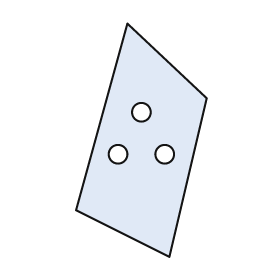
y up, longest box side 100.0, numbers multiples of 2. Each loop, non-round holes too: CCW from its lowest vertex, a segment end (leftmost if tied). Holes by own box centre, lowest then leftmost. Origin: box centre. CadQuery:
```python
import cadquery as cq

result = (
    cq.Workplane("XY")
    .moveTo(12.0, -50.0)
    .lineTo(28.0, 18.0)
    .lineTo(-6.0, 50.0)
    .lineTo(-28.0, -30.0)
    .close()
    .moveTo(-10.0, -6.0)
    .circle(4.0)
    .moveTo(10.0, -6.0)
    .circle(4.0)
    .moveTo(0.0, 12.0)
    .circle(4.0)
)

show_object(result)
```